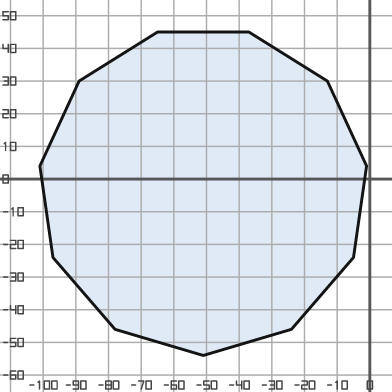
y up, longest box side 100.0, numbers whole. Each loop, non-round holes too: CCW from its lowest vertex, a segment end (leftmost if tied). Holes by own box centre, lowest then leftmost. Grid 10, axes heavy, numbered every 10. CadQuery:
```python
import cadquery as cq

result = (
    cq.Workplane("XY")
    .moveTo(-51.0, -54.0)
    .lineTo(-24.0, -46.0)
    .lineTo(-5.0, -24.0)
    .lineTo(-1.0, 4.0)
    .lineTo(-13.0, 30.0)
    .lineTo(-37.0, 45.0)
    .lineTo(-65.0, 45.0)
    .lineTo(-89.0, 30.0)
    .lineTo(-101.0, 4.0)
    .lineTo(-97.0, -24.0)
    .lineTo(-78.0, -46.0)
    .close()
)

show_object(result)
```